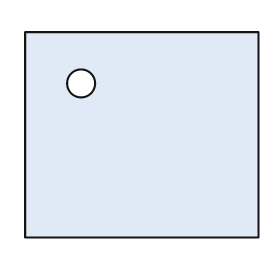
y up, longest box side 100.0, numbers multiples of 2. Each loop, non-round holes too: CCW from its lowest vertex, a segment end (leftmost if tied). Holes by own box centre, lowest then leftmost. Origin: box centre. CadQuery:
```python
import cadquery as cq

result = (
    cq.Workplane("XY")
    .moveTo(-50.0, -44.0)
    .lineTo(50.0, -44.0)
    .lineTo(50.0, 44.0)
    .lineTo(-50.0, 44.0)
    .close()
    .moveTo(-26.0, 22.0)
    .circle(6.0)
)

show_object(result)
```